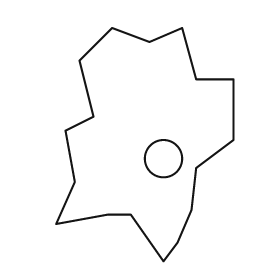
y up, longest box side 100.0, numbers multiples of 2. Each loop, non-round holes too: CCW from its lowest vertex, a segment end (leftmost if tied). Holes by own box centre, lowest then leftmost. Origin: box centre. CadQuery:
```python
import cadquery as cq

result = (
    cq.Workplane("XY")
    .moveTo(8.0, -50.0)
    .lineTo(14.0, -42.0)
    .lineTo(20.0, -28.0)
    .lineTo(22.0, -10.0)
    .lineTo(38.0, 2.0)
    .lineTo(38.0, 28.0)
    .lineTo(22.0, 28.0)
    .lineTo(16.0, 50.0)
    .lineTo(2.0, 44.0)
    .lineTo(-14.0, 50.0)
    .lineTo(-28.0, 36.0)
    .lineTo(-22.0, 12.0)
    .lineTo(-34.0, 6.0)
    .lineTo(-30.0, -16.0)
    .lineTo(-38.0, -34.0)
    .lineTo(-16.0, -30.0)
    .lineTo(-6.0, -30.0)
    .close()
    .moveTo(8.0, -6.0)
    .circle(8.0)
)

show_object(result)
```